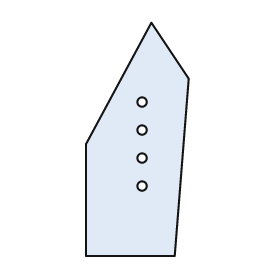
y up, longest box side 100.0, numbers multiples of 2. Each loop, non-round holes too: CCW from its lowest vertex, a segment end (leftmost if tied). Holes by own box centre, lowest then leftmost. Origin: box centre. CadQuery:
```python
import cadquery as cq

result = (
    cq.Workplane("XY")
    .moveTo(-22.0, -50.0)
    .lineTo(16.0, -50.0)
    .lineTo(22.0, 26.0)
    .lineTo(6.0, 50.0)
    .lineTo(-22.0, -2.0)
    .close()
    .moveTo(2.0, -20.0)
    .circle(2.0)
    .moveTo(2.0, -8.0)
    .circle(2.0)
    .moveTo(2.0, 4.0)
    .circle(2.0)
    .moveTo(2.0, 16.0)
    .circle(2.0)
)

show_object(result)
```